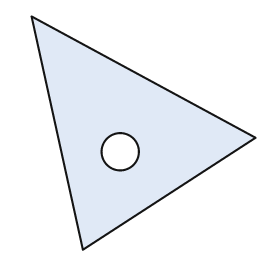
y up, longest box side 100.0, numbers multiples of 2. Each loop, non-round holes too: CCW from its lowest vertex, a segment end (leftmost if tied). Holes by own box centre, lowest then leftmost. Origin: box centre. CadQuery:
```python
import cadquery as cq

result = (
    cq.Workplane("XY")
    .moveTo(-26.0, -50.0)
    .lineTo(48.0, -2.0)
    .lineTo(-48.0, 50.0)
    .close()
    .moveTo(-10.0, -8.0)
    .circle(8.0)
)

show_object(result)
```